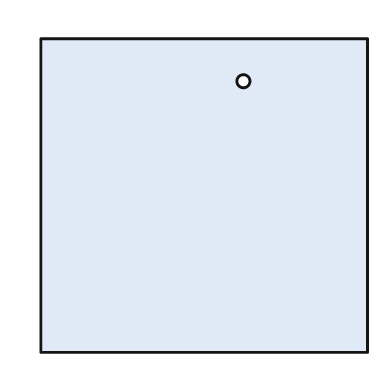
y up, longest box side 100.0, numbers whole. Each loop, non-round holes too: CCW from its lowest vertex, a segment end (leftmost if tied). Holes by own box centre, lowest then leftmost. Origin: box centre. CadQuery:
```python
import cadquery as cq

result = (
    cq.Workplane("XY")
    .moveTo(-50.0, -48.0)
    .lineTo(50.0, -48.0)
    .lineTo(50.0, 48.0)
    .lineTo(-50.0, 48.0)
    .close()
    .moveTo(12.0, 35.0)
    .circle(2.0)
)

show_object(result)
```